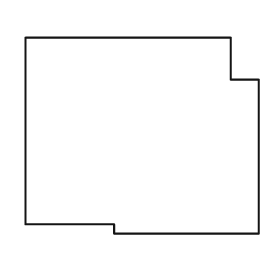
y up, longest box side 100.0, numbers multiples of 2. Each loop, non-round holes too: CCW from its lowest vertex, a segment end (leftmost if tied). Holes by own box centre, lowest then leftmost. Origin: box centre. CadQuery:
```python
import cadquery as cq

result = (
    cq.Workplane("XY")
    .moveTo(-12.0, -42.0)
    .lineTo(50.0, -42.0)
    .lineTo(50.0, 24.0)
    .lineTo(38.0, 24.0)
    .lineTo(38.0, 42.0)
    .lineTo(-50.0, 42.0)
    .lineTo(-50.0, -38.0)
    .lineTo(-12.0, -38.0)
    .close()
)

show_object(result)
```